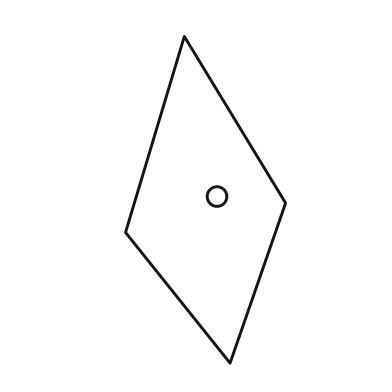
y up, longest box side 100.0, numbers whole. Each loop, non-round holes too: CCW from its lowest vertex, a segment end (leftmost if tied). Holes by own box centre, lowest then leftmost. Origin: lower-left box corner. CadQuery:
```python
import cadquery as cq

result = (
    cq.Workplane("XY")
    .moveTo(32.0, 0.0)
    .lineTo(49.0, 49.0)
    .lineTo(18.0, 100.0)
    .lineTo(0.0, 40.0)
    .close()
    .moveTo(28.0, 51.0)
    .circle(3.0)
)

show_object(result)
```